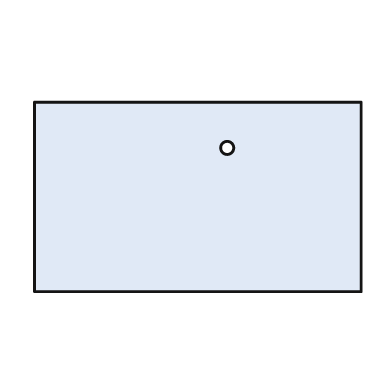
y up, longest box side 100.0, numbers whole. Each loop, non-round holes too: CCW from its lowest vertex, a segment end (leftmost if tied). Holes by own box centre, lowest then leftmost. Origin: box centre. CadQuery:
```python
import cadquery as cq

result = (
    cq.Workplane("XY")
    .moveTo(-50.0, -29.0)
    .lineTo(50.0, -29.0)
    .lineTo(50.0, 29.0)
    .lineTo(-50.0, 29.0)
    .close()
    .moveTo(9.0, 15.0)
    .circle(2.0)
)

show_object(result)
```